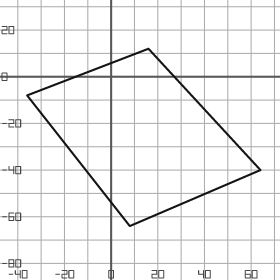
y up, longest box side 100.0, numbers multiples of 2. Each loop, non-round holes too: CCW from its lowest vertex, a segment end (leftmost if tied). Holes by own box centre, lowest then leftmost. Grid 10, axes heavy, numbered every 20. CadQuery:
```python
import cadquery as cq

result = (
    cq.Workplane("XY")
    .moveTo(8.0, -64.0)
    .lineTo(64.0, -40.0)
    .lineTo(16.0, 12.0)
    .lineTo(-36.0, -8.0)
    .close()
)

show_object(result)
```